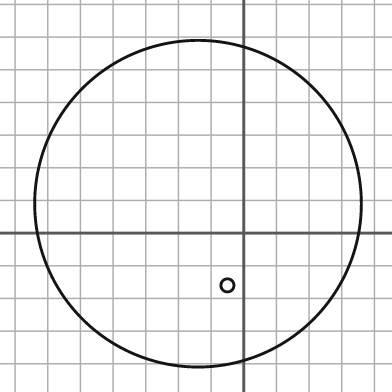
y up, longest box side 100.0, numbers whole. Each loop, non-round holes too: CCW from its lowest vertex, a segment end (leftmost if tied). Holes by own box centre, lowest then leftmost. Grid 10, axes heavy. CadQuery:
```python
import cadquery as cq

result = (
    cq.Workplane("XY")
    .moveTo(-14.0, 9.0)
    .circle(50.0)
    .moveTo(-5.0, -16.0)
    .circle(2.0)
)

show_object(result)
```